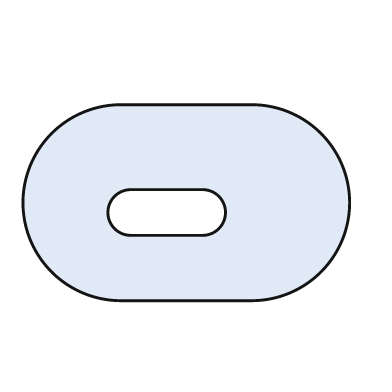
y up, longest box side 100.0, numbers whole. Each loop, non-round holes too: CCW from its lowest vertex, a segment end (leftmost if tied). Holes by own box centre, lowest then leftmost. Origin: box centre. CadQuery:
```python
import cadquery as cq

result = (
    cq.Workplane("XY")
    .moveTo(-20.0, -30.0)
    .lineTo(20.0, -30.0)
    .threePointArc((50.0, 0.0), (20.0, 30.0))
    .lineTo(-20.0, 30.0)
    .threePointArc((-50.0, 0.0), (-20.0, -30.0))
    .close()
    .moveTo(-17.0, -10.0)
    .lineTo(5.0, -10.0)
    .threePointArc((12.0, -3.0), (5.0, 4.0))
    .lineTo(-17.0, 4.0)
    .threePointArc((-24.0, -3.0), (-17.0, -10.0))
    .close()
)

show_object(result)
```